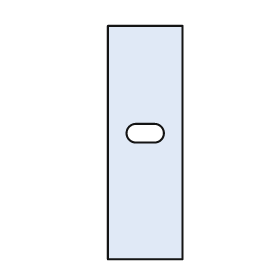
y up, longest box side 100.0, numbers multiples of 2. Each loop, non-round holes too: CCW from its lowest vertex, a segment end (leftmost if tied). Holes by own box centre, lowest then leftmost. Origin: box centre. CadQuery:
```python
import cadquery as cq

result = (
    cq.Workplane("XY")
    .moveTo(-16.0, -50.0)
    .lineTo(16.0, -50.0)
    .lineTo(16.0, 50.0)
    .lineTo(-16.0, 50.0)
    .close()
    .moveTo(-4.0, 0.0)
    .lineTo(4.0, 0.0)
    .threePointArc((8.0, 4.0), (4.0, 8.0))
    .lineTo(-4.0, 8.0)
    .threePointArc((-8.0, 4.0), (-4.0, 0.0))
    .close()
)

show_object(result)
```